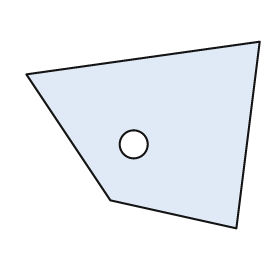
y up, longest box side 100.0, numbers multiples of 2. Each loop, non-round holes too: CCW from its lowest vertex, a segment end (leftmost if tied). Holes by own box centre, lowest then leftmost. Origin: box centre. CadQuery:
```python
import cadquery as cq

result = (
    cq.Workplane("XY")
    .moveTo(40.0, -40.0)
    .lineTo(50.0, 40.0)
    .lineTo(-50.0, 26.0)
    .lineTo(-14.0, -28.0)
    .close()
    .moveTo(-4.0, -4.0)
    .circle(6.0)
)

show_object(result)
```